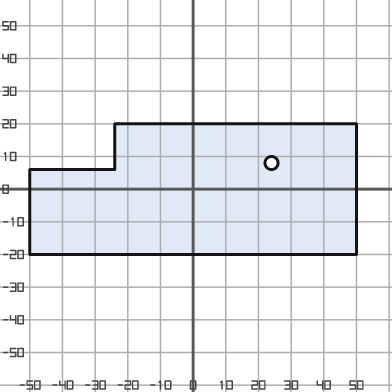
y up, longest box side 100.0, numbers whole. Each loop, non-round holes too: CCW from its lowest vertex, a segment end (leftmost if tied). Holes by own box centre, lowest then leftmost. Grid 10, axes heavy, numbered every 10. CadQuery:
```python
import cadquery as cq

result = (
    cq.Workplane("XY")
    .moveTo(-50.0, -20.0)
    .lineTo(50.0, -20.0)
    .lineTo(50.0, 20.0)
    .lineTo(-24.0, 20.0)
    .lineTo(-24.0, 6.0)
    .lineTo(-50.0, 6.0)
    .close()
    .moveTo(24.0, 8.0)
    .circle(2.0)
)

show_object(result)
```